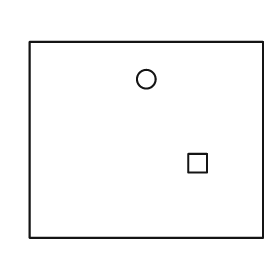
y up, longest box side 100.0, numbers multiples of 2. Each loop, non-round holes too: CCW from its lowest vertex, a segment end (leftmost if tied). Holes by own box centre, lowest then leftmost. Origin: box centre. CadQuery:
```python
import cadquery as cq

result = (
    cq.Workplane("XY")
    .moveTo(-50.0, -42.0)
    .lineTo(50.0, -42.0)
    .lineTo(50.0, 42.0)
    .lineTo(-50.0, 42.0)
    .close()
    .moveTo(18.0, -14.0)
    .lineTo(26.0, -14.0)
    .lineTo(26.0, -6.0)
    .lineTo(18.0, -6.0)
    .close()
    .moveTo(0.0, 26.0)
    .circle(4.0)
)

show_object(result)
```